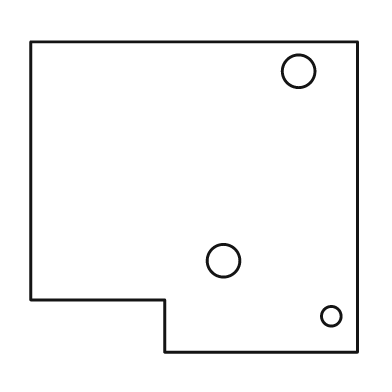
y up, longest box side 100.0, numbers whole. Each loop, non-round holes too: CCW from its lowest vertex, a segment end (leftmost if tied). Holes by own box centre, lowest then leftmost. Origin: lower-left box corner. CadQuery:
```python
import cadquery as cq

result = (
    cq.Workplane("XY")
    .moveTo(41.0, 0.0)
    .lineTo(100.0, 0.0)
    .lineTo(100.0, 95.0)
    .lineTo(0.0, 95.0)
    .lineTo(0.0, 16.0)
    .lineTo(41.0, 16.0)
    .close()
    .moveTo(92.0, 11.0)
    .circle(3.0)
    .moveTo(59.0, 28.0)
    .circle(5.0)
    .moveTo(82.0, 86.0)
    .circle(5.0)
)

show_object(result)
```